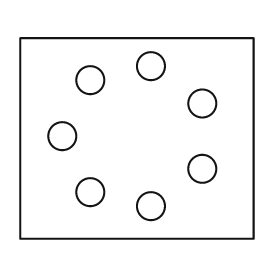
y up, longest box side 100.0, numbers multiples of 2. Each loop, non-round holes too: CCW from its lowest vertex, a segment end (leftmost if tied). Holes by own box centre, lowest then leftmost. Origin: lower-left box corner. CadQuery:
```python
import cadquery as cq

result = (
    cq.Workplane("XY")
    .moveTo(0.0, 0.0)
    .lineTo(100.0, 0.0)
    .lineTo(100.0, 86.0)
    .lineTo(0.0, 86.0)
    .close()
    .moveTo(56.0, 14.0)
    .circle(6.0)
    .moveTo(30.0, 20.0)
    .circle(6.0)
    .moveTo(78.0, 30.0)
    .circle(6.0)
    .moveTo(18.0, 44.0)
    .circle(6.0)
    .moveTo(78.0, 58.0)
    .circle(6.0)
    .moveTo(30.0, 68.0)
    .circle(6.0)
    .moveTo(56.0, 74.0)
    .circle(6.0)
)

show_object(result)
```